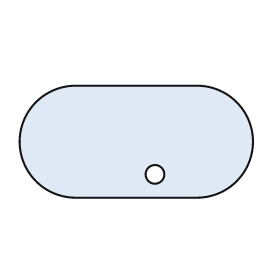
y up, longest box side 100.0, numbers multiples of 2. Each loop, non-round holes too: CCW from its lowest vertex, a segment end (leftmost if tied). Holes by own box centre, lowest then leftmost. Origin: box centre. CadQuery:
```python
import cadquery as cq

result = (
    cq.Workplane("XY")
    .moveTo(-26.0, -24.0)
    .lineTo(26.0, -24.0)
    .threePointArc((50.0, 0.0), (26.0, 24.0))
    .lineTo(-26.0, 24.0)
    .threePointArc((-50.0, 0.0), (-26.0, -24.0))
    .close()
    .moveTo(8.0, -14.0)
    .circle(4.0)
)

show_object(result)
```